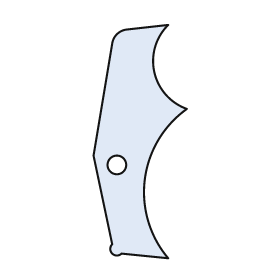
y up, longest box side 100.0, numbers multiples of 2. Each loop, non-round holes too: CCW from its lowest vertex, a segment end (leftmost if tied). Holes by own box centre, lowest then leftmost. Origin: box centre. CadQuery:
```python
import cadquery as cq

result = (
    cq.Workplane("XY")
    .moveTo(12.0, -50.0)
    .threePointArc((2.0, -16.0), (20.0, 14.0))
    .threePointArc((6.0, 30.0), (12.0, 50.0))
    .lineTo(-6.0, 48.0)
    .threePointArc((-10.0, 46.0), (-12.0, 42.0))
    .lineTo(-20.0, -6.0)
    .lineTo(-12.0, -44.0)
    .threePointArc((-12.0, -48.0), (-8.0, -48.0))
    .close()
    .moveTo(-10.0, -10.0)
    .circle(4.0)
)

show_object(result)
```